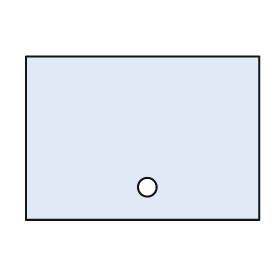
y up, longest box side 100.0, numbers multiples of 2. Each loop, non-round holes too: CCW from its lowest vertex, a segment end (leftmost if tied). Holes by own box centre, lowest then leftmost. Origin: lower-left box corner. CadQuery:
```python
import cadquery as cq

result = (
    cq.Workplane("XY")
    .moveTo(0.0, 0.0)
    .lineTo(100.0, 0.0)
    .lineTo(100.0, 70.0)
    .lineTo(0.0, 70.0)
    .close()
    .moveTo(52.0, 14.0)
    .circle(4.0)
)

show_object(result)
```